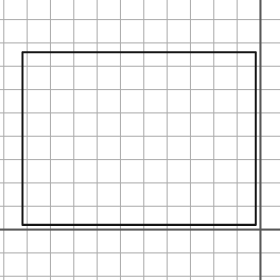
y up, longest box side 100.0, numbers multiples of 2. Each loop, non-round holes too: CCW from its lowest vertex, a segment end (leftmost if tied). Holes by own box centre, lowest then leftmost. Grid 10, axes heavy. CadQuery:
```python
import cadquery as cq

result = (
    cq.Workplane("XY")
    .moveTo(-102.0, 2.0)
    .lineTo(-2.0, 2.0)
    .lineTo(-2.0, 76.0)
    .lineTo(-102.0, 76.0)
    .close()
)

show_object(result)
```